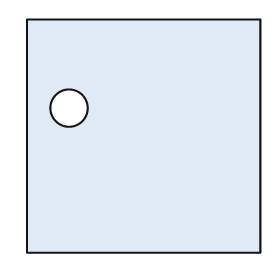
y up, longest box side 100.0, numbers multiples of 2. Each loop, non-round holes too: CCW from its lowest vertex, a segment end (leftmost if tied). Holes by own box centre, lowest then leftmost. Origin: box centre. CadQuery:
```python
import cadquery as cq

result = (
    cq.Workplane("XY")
    .moveTo(-50.0, -50.0)
    .lineTo(50.0, -50.0)
    .lineTo(50.0, 50.0)
    .lineTo(-50.0, 50.0)
    .close()
    .moveTo(-32.0, 12.0)
    .circle(8.0)
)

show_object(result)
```